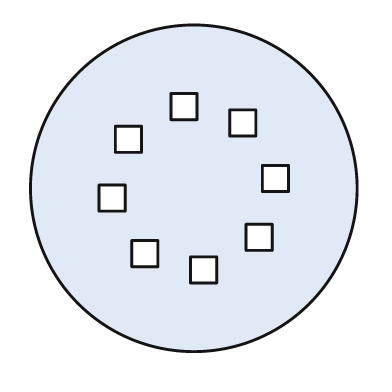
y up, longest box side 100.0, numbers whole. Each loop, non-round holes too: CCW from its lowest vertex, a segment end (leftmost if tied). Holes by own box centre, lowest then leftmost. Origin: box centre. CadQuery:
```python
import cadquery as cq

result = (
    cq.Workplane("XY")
    .moveTo(0.0, 0.0)
    .circle(50.0)
    .moveTo(-1.0, -29.0)
    .lineTo(7.0, -29.0)
    .lineTo(7.0, -21.0)
    .lineTo(-1.0, -21.0)
    .close()
    .moveTo(-19.0, -24.0)
    .lineTo(-11.0, -24.0)
    .lineTo(-11.0, -16.0)
    .lineTo(-19.0, -16.0)
    .close()
    .moveTo(16.0, -19.0)
    .lineTo(24.0, -19.0)
    .lineTo(24.0, -11.0)
    .lineTo(16.0, -11.0)
    .close()
    .moveTo(-29.0, -7.0)
    .lineTo(-21.0, -7.0)
    .lineTo(-21.0, 1.0)
    .lineTo(-29.0, 1.0)
    .close()
    .moveTo(21.0, -1.0)
    .lineTo(29.0, -1.0)
    .lineTo(29.0, 7.0)
    .lineTo(21.0, 7.0)
    .close()
    .moveTo(-24.0, 11.0)
    .lineTo(-16.0, 11.0)
    .lineTo(-16.0, 19.0)
    .lineTo(-24.0, 19.0)
    .close()
    .moveTo(11.0, 16.0)
    .lineTo(19.0, 16.0)
    .lineTo(19.0, 24.0)
    .lineTo(11.0, 24.0)
    .close()
    .moveTo(-7.0, 21.0)
    .lineTo(1.0, 21.0)
    .lineTo(1.0, 29.0)
    .lineTo(-7.0, 29.0)
    .close()
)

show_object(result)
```